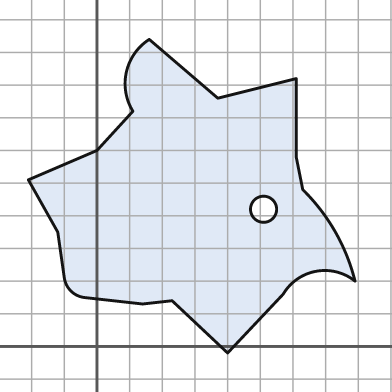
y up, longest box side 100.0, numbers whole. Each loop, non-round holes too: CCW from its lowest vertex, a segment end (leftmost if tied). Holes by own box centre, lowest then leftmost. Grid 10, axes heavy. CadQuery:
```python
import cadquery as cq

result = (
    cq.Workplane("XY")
    .moveTo(40.0, -2.0)
    .lineTo(57.0, 16.0)
    .threePointArc((67.0, 23.0), (79.0, 20.0))
    .threePointArc((73.0, 35.0), (63.0, 48.0))
    .lineTo(61.0, 58.0)
    .lineTo(61.0, 82.0)
    .lineTo(37.0, 76.0)
    .lineTo(16.0, 94.0)
    .threePointArc((9.0, 84.0), (11.0, 72.0))
    .lineTo(0.0, 60.0)
    .lineTo(-21.0, 51.0)
    .lineTo(-12.0, 35.0)
    .lineTo(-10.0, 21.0)
    .threePointArc((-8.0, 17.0), (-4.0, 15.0))
    .lineTo(14.0, 13.0)
    .lineTo(23.0, 14.0)
    .close()
    .moveTo(51.0, 42.0)
    .circle(4.0)
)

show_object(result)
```